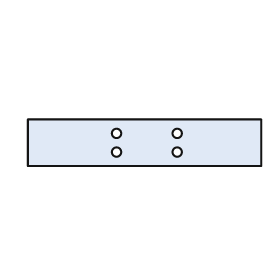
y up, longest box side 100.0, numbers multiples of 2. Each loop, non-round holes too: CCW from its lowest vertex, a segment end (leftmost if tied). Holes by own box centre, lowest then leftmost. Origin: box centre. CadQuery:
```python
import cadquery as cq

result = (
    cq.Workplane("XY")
    .moveTo(-50.0, -10.0)
    .lineTo(50.0, -10.0)
    .lineTo(50.0, 10.0)
    .lineTo(-50.0, 10.0)
    .close()
    .moveTo(-12.0, -4.0)
    .circle(2.0)
    .moveTo(14.0, -4.0)
    .circle(2.0)
    .moveTo(-12.0, 4.0)
    .circle(2.0)
    .moveTo(14.0, 4.0)
    .circle(2.0)
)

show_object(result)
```